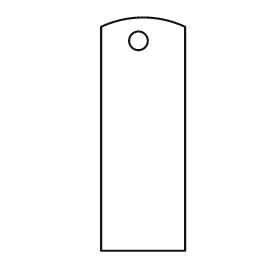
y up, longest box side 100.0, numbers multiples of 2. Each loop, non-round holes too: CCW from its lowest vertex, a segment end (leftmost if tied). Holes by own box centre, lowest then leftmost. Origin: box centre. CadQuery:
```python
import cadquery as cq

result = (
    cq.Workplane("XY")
    .moveTo(-18.0, -50.0)
    .lineTo(18.0, -50.0)
    .lineTo(18.0, 46.0)
    .threePointArc((0.0, 50.0), (-18.0, 46.0))
    .close()
    .moveTo(-2.0, 40.0)
    .circle(4.0)
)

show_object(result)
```